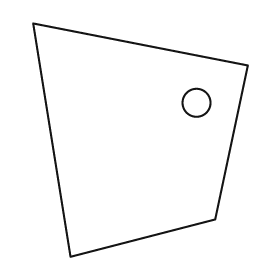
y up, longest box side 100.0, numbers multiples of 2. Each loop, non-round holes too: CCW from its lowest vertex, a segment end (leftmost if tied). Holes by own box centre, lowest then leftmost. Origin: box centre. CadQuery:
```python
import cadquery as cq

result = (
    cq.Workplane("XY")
    .moveTo(-30.0, -50.0)
    .lineTo(32.0, -34.0)
    .lineTo(46.0, 32.0)
    .lineTo(-46.0, 50.0)
    .close()
    .moveTo(24.0, 16.0)
    .circle(6.0)
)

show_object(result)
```